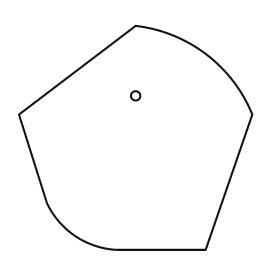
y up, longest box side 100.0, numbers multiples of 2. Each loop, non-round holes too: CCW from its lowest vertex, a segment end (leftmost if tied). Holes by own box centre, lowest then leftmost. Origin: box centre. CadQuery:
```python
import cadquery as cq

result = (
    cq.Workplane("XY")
    .moveTo(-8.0, -48.0)
    .lineTo(30.0, -48.0)
    .lineTo(50.0, 10.0)
    .threePointArc((30.0, 36.0), (0.0, 48.0))
    .lineTo(-50.0, 10.0)
    .lineTo(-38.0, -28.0)
    .threePointArc((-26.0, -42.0), (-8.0, -48.0))
    .close()
    .moveTo(0.0, 18.0)
    .circle(2.0)
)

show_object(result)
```